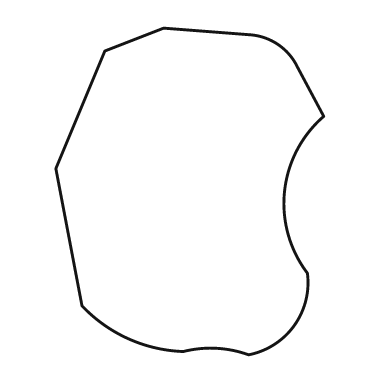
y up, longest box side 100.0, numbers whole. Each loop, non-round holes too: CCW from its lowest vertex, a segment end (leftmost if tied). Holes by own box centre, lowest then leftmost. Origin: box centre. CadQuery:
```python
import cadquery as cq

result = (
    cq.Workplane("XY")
    .moveTo(18.0, -50.0)
    .threePointArc((32.0, -41.0), (36.0, -25.0))
    .threePointArc((29.0, 0.0), (41.0, 23.0))
    .lineTo(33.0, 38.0)
    .threePointArc((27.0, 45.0), (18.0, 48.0))
    .lineTo(-8.0, 50.0)
    .lineTo(-26.0, 43.0)
    .lineTo(-41.0, 7.0)
    .lineTo(-33.0, -35.0)
    .threePointArc((-19.0, -45.0), (-2.0, -49.0))
    .threePointArc((8.0, -48.0), (18.0, -50.0))
    .close()
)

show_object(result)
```